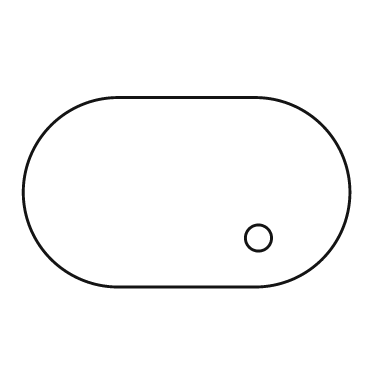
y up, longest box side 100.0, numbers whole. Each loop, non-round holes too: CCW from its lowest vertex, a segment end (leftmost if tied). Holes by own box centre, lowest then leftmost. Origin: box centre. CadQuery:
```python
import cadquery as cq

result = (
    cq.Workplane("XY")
    .moveTo(-21.0, -29.0)
    .lineTo(21.0, -29.0)
    .threePointArc((50.0, 0.0), (21.0, 29.0))
    .lineTo(-21.0, 29.0)
    .threePointArc((-50.0, 0.0), (-21.0, -29.0))
    .close()
    .moveTo(22.0, -14.0)
    .circle(4.0)
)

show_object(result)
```